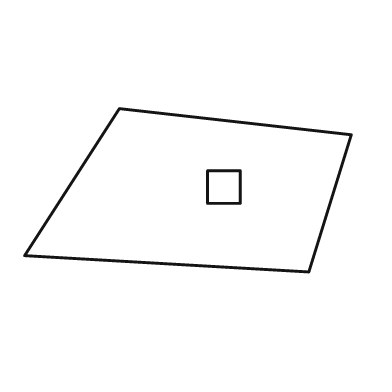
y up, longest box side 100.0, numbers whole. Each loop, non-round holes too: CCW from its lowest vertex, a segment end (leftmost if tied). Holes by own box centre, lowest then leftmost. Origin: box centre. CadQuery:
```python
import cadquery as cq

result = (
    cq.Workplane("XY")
    .moveTo(37.0, -25.0)
    .lineTo(50.0, 17.0)
    .lineTo(-21.0, 25.0)
    .lineTo(-50.0, -20.0)
    .close()
    .moveTo(6.0, -4.0)
    .lineTo(16.0, -4.0)
    .lineTo(16.0, 6.0)
    .lineTo(6.0, 6.0)
    .close()
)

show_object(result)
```